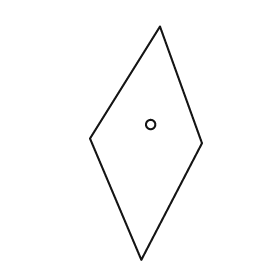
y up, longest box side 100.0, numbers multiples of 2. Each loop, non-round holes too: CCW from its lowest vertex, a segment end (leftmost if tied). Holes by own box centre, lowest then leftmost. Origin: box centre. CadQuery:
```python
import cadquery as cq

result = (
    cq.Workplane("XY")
    .moveTo(-2.0, -50.0)
    .lineTo(24.0, 0.0)
    .lineTo(6.0, 50.0)
    .lineTo(-24.0, 2.0)
    .close()
    .moveTo(2.0, 8.0)
    .circle(2.0)
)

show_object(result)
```